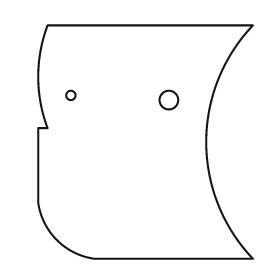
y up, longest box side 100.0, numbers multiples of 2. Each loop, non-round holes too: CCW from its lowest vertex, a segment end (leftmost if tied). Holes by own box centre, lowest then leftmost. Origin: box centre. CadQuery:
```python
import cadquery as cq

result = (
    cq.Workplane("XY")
    .moveTo(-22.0, -50.0)
    .lineTo(46.0, -50.0)
    .threePointArc((26.0, 0.0), (46.0, 50.0))
    .lineTo(-42.0, 50.0)
    .threePointArc((-46.0, 28.0), (-42.0, 6.0))
    .lineTo(-46.0, 6.0)
    .lineTo(-46.0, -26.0)
    .threePointArc((-38.0, -42.0), (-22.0, -50.0))
    .close()
    .moveTo(10.0, 18.0)
    .circle(4.0)
    .moveTo(-32.0, 20.0)
    .circle(2.0)
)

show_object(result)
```